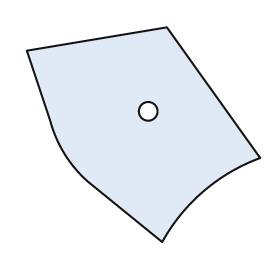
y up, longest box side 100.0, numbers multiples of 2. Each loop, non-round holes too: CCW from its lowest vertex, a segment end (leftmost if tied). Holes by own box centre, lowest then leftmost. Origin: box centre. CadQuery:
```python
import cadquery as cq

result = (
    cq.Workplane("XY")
    .moveTo(8.0, -46.0)
    .threePointArc((26.0, -24.0), (50.0, -10.0))
    .lineTo(10.0, 46.0)
    .lineTo(-50.0, 36.0)
    .lineTo(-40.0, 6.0)
    .threePointArc((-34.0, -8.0), (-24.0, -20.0))
    .close()
    .moveTo(2.0, 10.0)
    .circle(4.0)
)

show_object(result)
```